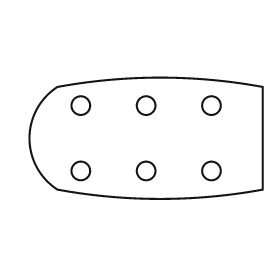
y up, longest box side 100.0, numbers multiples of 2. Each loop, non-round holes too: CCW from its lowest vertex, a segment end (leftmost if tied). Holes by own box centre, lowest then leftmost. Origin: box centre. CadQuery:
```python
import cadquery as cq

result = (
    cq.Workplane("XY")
    .moveTo(-38.0, -22.0)
    .threePointArc((6.0, -26.0), (50.0, -22.0))
    .lineTo(50.0, 22.0)
    .threePointArc((6.0, 26.0), (-38.0, 22.0))
    .threePointArc((-50.0, 0.0), (-38.0, -22.0))
    .close()
    .moveTo(-28.0, -14.0)
    .circle(4.0)
    .moveTo(0.0, -14.0)
    .circle(4.0)
    .moveTo(28.0, -14.0)
    .circle(4.0)
    .moveTo(-28.0, 14.0)
    .circle(4.0)
    .moveTo(0.0, 14.0)
    .circle(4.0)
    .moveTo(28.0, 14.0)
    .circle(4.0)
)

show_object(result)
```